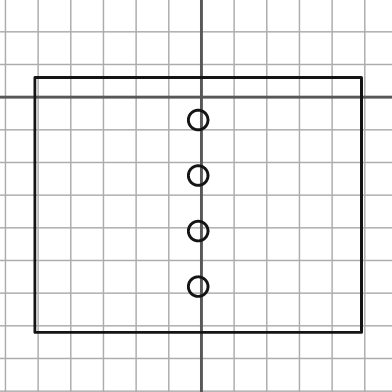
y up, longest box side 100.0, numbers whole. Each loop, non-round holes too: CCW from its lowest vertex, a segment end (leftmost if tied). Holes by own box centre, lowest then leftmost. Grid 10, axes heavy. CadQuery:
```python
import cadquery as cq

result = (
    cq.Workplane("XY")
    .moveTo(-51.0, -72.0)
    .lineTo(49.0, -72.0)
    .lineTo(49.0, 6.0)
    .lineTo(-51.0, 6.0)
    .close()
    .moveTo(-1.0, -58.0)
    .circle(3.0)
    .moveTo(-1.0, -41.0)
    .circle(3.0)
    .moveTo(-1.0, -24.0)
    .circle(3.0)
    .moveTo(-1.0, -7.0)
    .circle(3.0)
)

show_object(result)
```